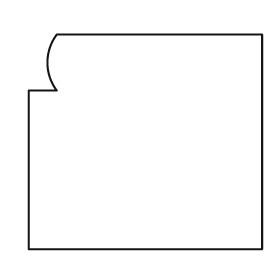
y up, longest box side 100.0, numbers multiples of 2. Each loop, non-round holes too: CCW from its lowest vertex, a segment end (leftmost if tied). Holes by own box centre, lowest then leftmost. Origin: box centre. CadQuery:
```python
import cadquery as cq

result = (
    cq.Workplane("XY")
    .moveTo(-50.0, -46.0)
    .lineTo(50.0, -46.0)
    .lineTo(50.0, 46.0)
    .lineTo(-38.0, 46.0)
    .threePointArc((-42.0, 34.0), (-38.0, 22.0))
    .lineTo(-50.0, 22.0)
    .close()
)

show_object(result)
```